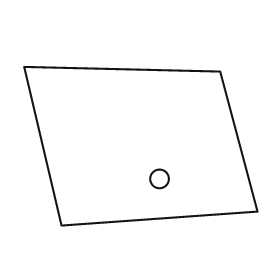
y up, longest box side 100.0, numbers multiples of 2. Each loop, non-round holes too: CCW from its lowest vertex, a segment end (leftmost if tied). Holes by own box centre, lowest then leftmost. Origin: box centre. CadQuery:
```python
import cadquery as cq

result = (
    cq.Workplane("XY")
    .moveTo(-34.0, -34.0)
    .lineTo(50.0, -28.0)
    .lineTo(34.0, 32.0)
    .lineTo(-50.0, 34.0)
    .close()
    .moveTo(8.0, -14.0)
    .circle(4.0)
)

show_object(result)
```